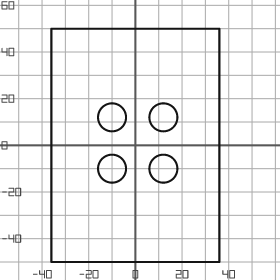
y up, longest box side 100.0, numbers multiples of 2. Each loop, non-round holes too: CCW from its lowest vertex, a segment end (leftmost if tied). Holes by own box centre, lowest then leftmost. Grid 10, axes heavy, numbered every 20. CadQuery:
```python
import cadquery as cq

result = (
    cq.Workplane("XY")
    .moveTo(-36.0, -50.0)
    .lineTo(36.0, -50.0)
    .lineTo(36.0, 50.0)
    .lineTo(-36.0, 50.0)
    .close()
    .moveTo(-10.0, -10.0)
    .circle(6.0)
    .moveTo(12.0, -10.0)
    .circle(6.0)
    .moveTo(-10.0, 12.0)
    .circle(6.0)
    .moveTo(12.0, 12.0)
    .circle(6.0)
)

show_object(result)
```